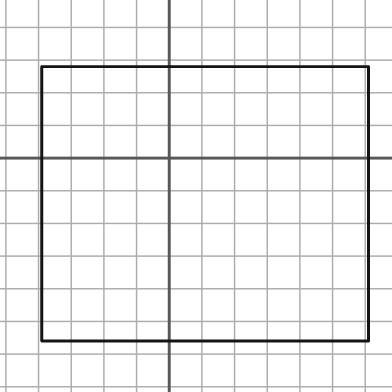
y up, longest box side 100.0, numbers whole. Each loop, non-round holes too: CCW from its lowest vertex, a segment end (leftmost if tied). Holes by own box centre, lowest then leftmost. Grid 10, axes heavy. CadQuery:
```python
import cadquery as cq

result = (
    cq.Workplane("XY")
    .moveTo(-39.0, -56.0)
    .lineTo(61.0, -56.0)
    .lineTo(61.0, 28.0)
    .lineTo(-39.0, 28.0)
    .close()
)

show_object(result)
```